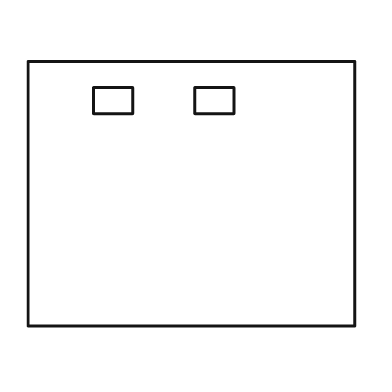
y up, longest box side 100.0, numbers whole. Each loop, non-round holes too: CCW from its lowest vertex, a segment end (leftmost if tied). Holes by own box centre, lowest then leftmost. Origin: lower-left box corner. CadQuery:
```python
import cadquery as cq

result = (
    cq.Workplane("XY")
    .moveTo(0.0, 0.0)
    .lineTo(100.0, 0.0)
    .lineTo(100.0, 81.0)
    .lineTo(0.0, 81.0)
    .close()
    .moveTo(20.0, 65.0)
    .lineTo(32.0, 65.0)
    .lineTo(32.0, 73.0)
    .lineTo(20.0, 73.0)
    .close()
    .moveTo(51.0, 65.0)
    .lineTo(63.0, 65.0)
    .lineTo(63.0, 73.0)
    .lineTo(51.0, 73.0)
    .close()
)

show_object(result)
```